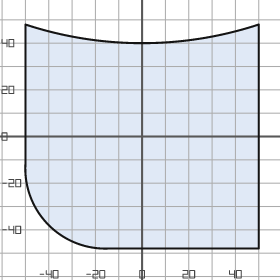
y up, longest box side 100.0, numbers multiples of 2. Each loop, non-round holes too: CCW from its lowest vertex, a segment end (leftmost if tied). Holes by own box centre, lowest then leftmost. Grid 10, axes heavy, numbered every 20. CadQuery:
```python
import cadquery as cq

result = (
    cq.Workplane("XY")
    .moveTo(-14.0, -48.0)
    .lineTo(50.0, -48.0)
    .lineTo(50.0, 48.0)
    .threePointArc((0.0, 40.0), (-50.0, 48.0))
    .lineTo(-50.0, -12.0)
    .threePointArc((-40.0, -38.0), (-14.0, -48.0))
    .close()
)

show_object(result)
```